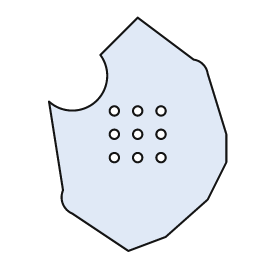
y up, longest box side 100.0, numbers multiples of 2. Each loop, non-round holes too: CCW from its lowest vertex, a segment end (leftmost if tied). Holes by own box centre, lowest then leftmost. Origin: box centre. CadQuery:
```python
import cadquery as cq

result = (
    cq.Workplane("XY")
    .moveTo(-4.0, -50.0)
    .lineTo(12.0, -44.0)
    .lineTo(30.0, -28.0)
    .lineTo(38.0, -12.0)
    .lineTo(38.0, 0.0)
    .lineTo(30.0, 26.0)
    .threePointArc((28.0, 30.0), (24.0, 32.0))
    .lineTo(0.0, 50.0)
    .lineTo(-16.0, 34.0)
    .threePointArc((-18.0, 14.0), (-38.0, 14.0))
    .lineTo(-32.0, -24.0)
    .threePointArc((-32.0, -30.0), (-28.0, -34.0))
    .close()
    .moveTo(-10.0, -10.0)
    .circle(2.0)
    .moveTo(0.0, -10.0)
    .circle(2.0)
    .moveTo(10.0, -10.0)
    .circle(2.0)
    .moveTo(-10.0, 0.0)
    .circle(2.0)
    .moveTo(0.0, 0.0)
    .circle(2.0)
    .moveTo(10.0, 0.0)
    .circle(2.0)
    .moveTo(-10.0, 10.0)
    .circle(2.0)
    .moveTo(0.0, 10.0)
    .circle(2.0)
    .moveTo(10.0, 10.0)
    .circle(2.0)
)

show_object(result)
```